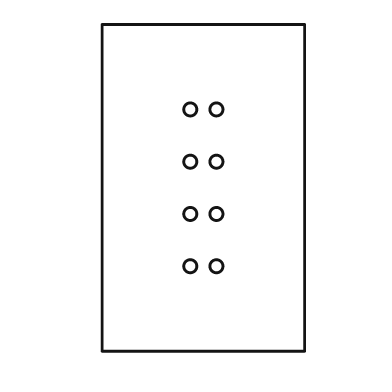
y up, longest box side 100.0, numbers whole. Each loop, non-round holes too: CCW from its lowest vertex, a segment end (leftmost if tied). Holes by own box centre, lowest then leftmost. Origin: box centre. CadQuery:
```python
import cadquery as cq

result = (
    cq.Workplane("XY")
    .moveTo(-31.0, -50.0)
    .lineTo(31.0, -50.0)
    .lineTo(31.0, 50.0)
    .lineTo(-31.0, 50.0)
    .close()
    .moveTo(-4.0, -24.0)
    .circle(2.0)
    .moveTo(4.0, -24.0)
    .circle(2.0)
    .moveTo(-4.0, -8.0)
    .circle(2.0)
    .moveTo(4.0, -8.0)
    .circle(2.0)
    .moveTo(-4.0, 8.0)
    .circle(2.0)
    .moveTo(4.0, 8.0)
    .circle(2.0)
    .moveTo(-4.0, 24.0)
    .circle(2.0)
    .moveTo(4.0, 24.0)
    .circle(2.0)
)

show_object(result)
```